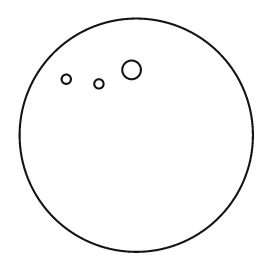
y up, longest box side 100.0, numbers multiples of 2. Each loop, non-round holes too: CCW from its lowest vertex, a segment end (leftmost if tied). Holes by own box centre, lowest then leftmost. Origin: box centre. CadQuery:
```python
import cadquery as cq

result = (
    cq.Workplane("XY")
    .moveTo(0.0, 0.0)
    .circle(50.0)
    .moveTo(-16.0, 22.0)
    .circle(2.0)
    .moveTo(-30.0, 24.0)
    .circle(2.0)
    .moveTo(-2.0, 28.0)
    .circle(4.0)
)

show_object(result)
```